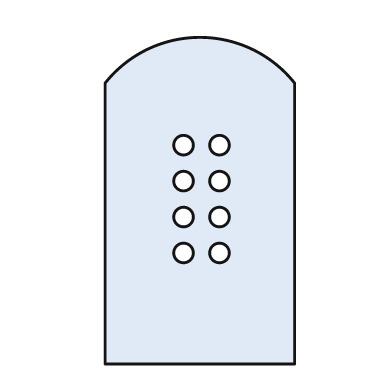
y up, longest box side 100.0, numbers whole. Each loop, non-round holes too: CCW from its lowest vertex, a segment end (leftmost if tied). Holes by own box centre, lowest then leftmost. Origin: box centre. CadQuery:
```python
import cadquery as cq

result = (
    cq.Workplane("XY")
    .moveTo(-29.0, -50.0)
    .lineTo(29.0, -50.0)
    .lineTo(29.0, 36.0)
    .threePointArc((0.0, 50.0), (-29.0, 36.0))
    .close()
    .moveTo(-5.0, -16.0)
    .circle(3.0)
    .moveTo(6.0, -16.0)
    .circle(3.0)
    .moveTo(-5.0, -5.0)
    .circle(3.0)
    .moveTo(6.0, -5.0)
    .circle(3.0)
    .moveTo(-5.0, 6.0)
    .circle(3.0)
    .moveTo(6.0, 6.0)
    .circle(3.0)
    .moveTo(-5.0, 17.0)
    .circle(3.0)
    .moveTo(6.0, 17.0)
    .circle(3.0)
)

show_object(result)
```